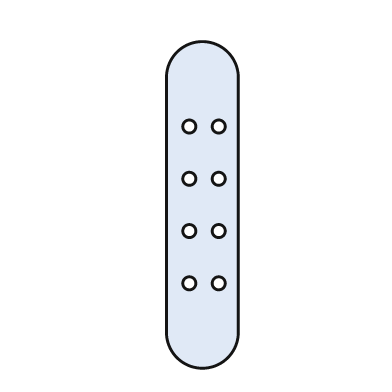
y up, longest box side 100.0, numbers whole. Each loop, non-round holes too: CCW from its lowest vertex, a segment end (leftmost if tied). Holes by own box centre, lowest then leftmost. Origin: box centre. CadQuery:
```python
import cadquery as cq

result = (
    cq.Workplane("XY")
    .moveTo(-11.0, -39.0)
    .threePointArc((0.0, -50.0), (11.0, -39.0))
    .lineTo(11.0, 39.0)
    .threePointArc((0.0, 50.0), (-11.0, 39.0))
    .close()
    .moveTo(-4.0, -24.0)
    .circle(2.0)
    .moveTo(5.0, -24.0)
    .circle(2.0)
    .moveTo(-4.0, -8.0)
    .circle(2.0)
    .moveTo(5.0, -8.0)
    .circle(2.0)
    .moveTo(-4.0, 8.0)
    .circle(2.0)
    .moveTo(5.0, 8.0)
    .circle(2.0)
    .moveTo(-4.0, 24.0)
    .circle(2.0)
    .moveTo(5.0, 24.0)
    .circle(2.0)
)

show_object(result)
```